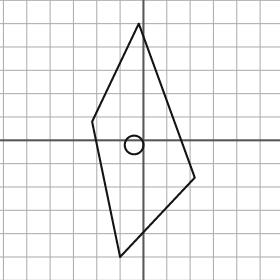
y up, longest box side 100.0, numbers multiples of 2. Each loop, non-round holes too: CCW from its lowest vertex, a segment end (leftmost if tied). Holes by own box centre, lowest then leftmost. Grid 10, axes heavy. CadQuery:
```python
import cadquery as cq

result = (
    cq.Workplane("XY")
    .moveTo(-10.0, -50.0)
    .lineTo(22.0, -16.0)
    .lineTo(-2.0, 50.0)
    .lineTo(-22.0, 8.0)
    .close()
    .moveTo(-4.0, -2.0)
    .circle(4.0)
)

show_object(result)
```